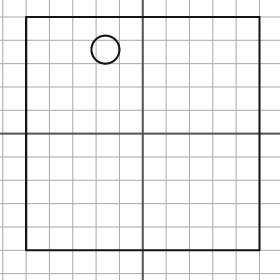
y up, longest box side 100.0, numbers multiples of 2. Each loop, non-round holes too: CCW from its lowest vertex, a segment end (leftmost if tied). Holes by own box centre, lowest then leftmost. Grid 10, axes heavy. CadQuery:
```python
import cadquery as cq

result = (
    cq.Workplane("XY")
    .moveTo(-50.0, -50.0)
    .lineTo(50.0, -50.0)
    .lineTo(50.0, 50.0)
    .lineTo(-50.0, 50.0)
    .close()
    .moveTo(-16.0, 36.0)
    .circle(6.0)
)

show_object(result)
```